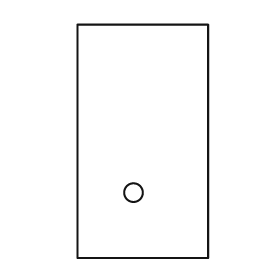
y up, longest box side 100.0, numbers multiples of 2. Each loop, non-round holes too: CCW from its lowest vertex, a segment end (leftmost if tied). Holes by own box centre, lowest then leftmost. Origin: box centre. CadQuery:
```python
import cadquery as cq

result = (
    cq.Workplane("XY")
    .moveTo(-28.0, -50.0)
    .lineTo(28.0, -50.0)
    .lineTo(28.0, 50.0)
    .lineTo(-28.0, 50.0)
    .close()
    .moveTo(-4.0, -22.0)
    .circle(4.0)
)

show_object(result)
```